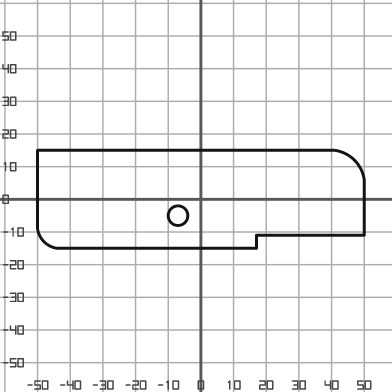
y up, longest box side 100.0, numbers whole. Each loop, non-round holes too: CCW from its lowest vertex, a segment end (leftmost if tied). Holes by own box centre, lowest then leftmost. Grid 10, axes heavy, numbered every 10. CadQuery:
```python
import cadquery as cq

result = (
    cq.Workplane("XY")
    .moveTo(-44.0, -15.0)
    .lineTo(17.0, -15.0)
    .lineTo(17.0, -11.0)
    .lineTo(50.0, -11.0)
    .lineTo(50.0, 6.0)
    .threePointArc((47.0, 12.0), (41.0, 15.0))
    .lineTo(-50.0, 15.0)
    .lineTo(-50.0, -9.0)
    .threePointArc((-48.0, -13.0), (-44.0, -15.0))
    .close()
    .moveTo(-7.0, -5.0)
    .circle(3.0)
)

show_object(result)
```